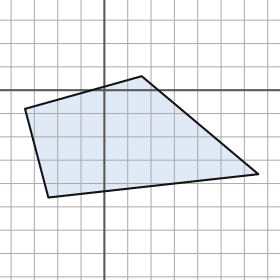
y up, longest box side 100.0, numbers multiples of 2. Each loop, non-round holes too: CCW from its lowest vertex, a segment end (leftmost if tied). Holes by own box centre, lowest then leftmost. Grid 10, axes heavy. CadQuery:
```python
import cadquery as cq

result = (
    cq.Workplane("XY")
    .moveTo(-24.0, -46.0)
    .lineTo(66.0, -36.0)
    .lineTo(16.0, 6.0)
    .lineTo(-34.0, -8.0)
    .close()
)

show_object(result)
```